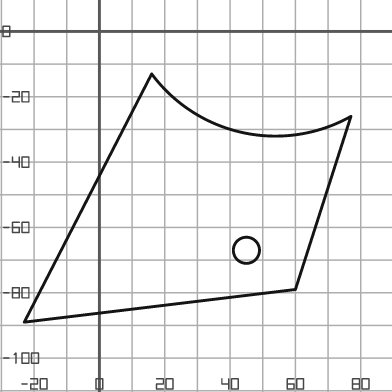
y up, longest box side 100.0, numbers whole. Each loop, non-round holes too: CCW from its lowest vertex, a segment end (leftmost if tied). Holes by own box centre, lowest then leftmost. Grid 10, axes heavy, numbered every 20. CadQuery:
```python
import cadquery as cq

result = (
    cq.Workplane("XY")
    .moveTo(-23.0, -89.0)
    .lineTo(60.0, -79.0)
    .lineTo(77.0, -26.0)
    .threePointArc((44.0, -31.0), (16.0, -13.0))
    .close()
    .moveTo(45.0, -67.0)
    .circle(4.0)
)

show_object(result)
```